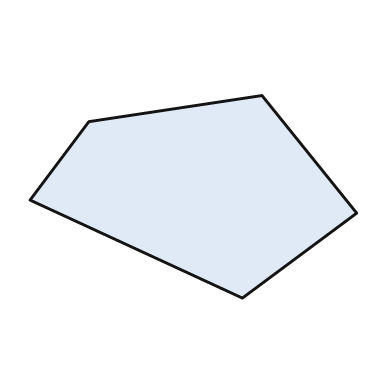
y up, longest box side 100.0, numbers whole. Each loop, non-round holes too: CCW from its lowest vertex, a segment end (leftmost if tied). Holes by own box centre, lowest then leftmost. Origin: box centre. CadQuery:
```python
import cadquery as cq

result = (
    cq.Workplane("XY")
    .moveTo(15.0, -31.0)
    .lineTo(50.0, -5.0)
    .lineTo(21.0, 31.0)
    .lineTo(-32.0, 23.0)
    .lineTo(-50.0, -1.0)
    .close()
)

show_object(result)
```